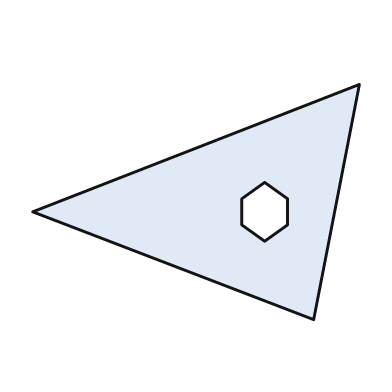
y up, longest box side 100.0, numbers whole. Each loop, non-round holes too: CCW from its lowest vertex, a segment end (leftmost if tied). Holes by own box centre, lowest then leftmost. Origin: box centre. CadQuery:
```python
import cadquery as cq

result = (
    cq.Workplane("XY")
    .moveTo(36.0, -36.0)
    .lineTo(50.0, 36.0)
    .lineTo(-50.0, -3.0)
    .close()
    .moveTo(21.0, -12.0)
    .lineTo(28.0, -7.0)
    .lineTo(28.0, 1.0)
    .lineTo(21.0, 6.0)
    .lineTo(14.0, 1.0)
    .lineTo(14.0, -7.0)
    .close()
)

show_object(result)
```